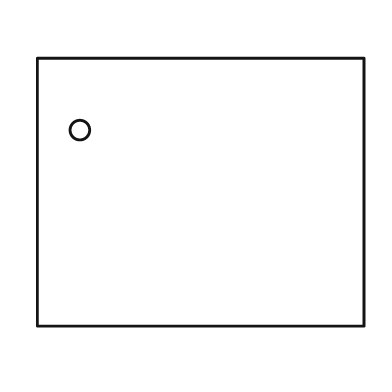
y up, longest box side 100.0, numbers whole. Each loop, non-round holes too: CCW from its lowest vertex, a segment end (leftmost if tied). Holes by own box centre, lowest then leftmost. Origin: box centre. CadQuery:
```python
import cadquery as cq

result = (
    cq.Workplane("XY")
    .moveTo(-50.0, -41.0)
    .lineTo(50.0, -41.0)
    .lineTo(50.0, 41.0)
    .lineTo(-50.0, 41.0)
    .close()
    .moveTo(-37.0, 19.0)
    .circle(3.0)
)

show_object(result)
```